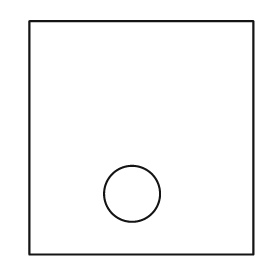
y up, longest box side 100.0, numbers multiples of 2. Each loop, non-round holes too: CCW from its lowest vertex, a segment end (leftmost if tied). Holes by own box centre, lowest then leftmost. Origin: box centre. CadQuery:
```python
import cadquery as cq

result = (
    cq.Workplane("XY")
    .moveTo(-48.0, -50.0)
    .lineTo(48.0, -50.0)
    .lineTo(48.0, 50.0)
    .lineTo(-48.0, 50.0)
    .close()
    .moveTo(-4.0, -24.0)
    .circle(12.0)
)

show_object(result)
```